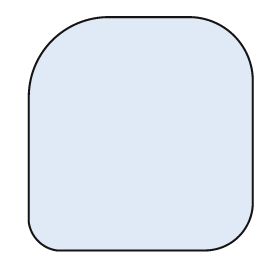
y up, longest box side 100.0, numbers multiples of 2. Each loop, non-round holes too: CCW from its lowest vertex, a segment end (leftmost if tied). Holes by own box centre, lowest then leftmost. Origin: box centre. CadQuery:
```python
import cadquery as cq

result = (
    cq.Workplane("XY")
    .moveTo(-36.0, -50.0)
    .lineTo(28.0, -50.0)
    .threePointArc((42.0, -44.0), (48.0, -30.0))
    .lineTo(48.0, 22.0)
    .threePointArc((40.0, 42.0), (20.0, 50.0))
    .lineTo(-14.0, 50.0)
    .threePointArc((-38.0, 40.0), (-48.0, 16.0))
    .lineTo(-48.0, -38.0)
    .threePointArc((-44.0, -46.0), (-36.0, -50.0))
    .close()
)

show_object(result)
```